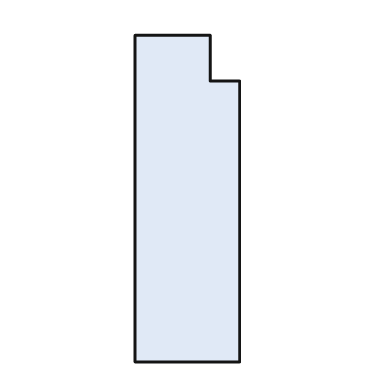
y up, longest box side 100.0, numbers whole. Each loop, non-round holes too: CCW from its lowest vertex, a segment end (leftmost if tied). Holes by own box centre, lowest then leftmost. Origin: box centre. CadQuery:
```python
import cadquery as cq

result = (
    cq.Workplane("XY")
    .moveTo(-16.0, -50.0)
    .lineTo(16.0, -50.0)
    .lineTo(16.0, 36.0)
    .lineTo(7.0, 36.0)
    .lineTo(7.0, 50.0)
    .lineTo(-16.0, 50.0)
    .close()
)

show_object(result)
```